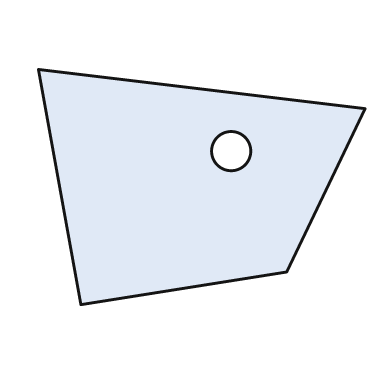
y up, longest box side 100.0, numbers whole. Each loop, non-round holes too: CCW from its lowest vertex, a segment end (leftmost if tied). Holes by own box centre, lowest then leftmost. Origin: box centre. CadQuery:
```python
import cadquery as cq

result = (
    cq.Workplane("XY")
    .moveTo(-37.0, -36.0)
    .lineTo(26.0, -26.0)
    .lineTo(50.0, 24.0)
    .lineTo(-50.0, 36.0)
    .close()
    .moveTo(9.0, 11.0)
    .circle(6.0)
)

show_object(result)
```